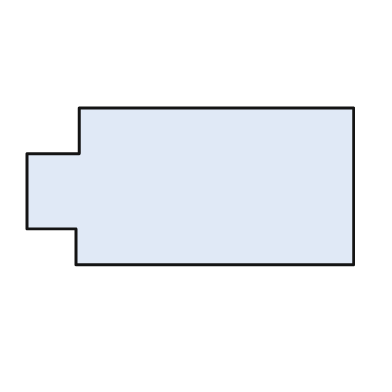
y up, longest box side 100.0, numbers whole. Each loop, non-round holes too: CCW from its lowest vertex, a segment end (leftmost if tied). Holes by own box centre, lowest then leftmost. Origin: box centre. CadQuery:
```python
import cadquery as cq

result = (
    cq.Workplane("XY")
    .moveTo(-35.0, -24.0)
    .lineTo(50.0, -24.0)
    .lineTo(50.0, 24.0)
    .lineTo(-34.0, 24.0)
    .lineTo(-34.0, 10.0)
    .lineTo(-50.0, 10.0)
    .lineTo(-50.0, -13.0)
    .lineTo(-35.0, -13.0)
    .close()
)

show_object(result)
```